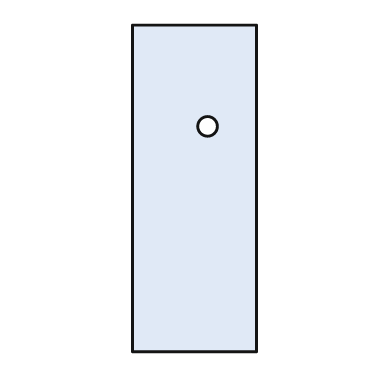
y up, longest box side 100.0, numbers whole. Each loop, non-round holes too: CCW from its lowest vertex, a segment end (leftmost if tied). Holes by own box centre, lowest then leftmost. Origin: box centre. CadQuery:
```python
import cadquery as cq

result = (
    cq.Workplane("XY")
    .moveTo(-19.0, -50.0)
    .lineTo(19.0, -50.0)
    .lineTo(19.0, 50.0)
    .lineTo(-19.0, 50.0)
    .close()
    .moveTo(4.0, 19.0)
    .circle(3.0)
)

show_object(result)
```